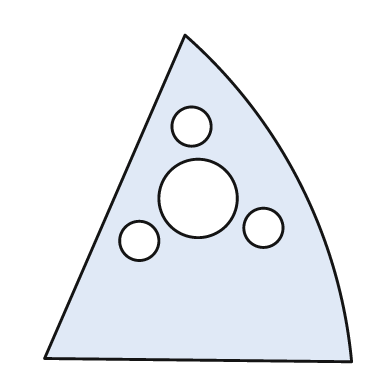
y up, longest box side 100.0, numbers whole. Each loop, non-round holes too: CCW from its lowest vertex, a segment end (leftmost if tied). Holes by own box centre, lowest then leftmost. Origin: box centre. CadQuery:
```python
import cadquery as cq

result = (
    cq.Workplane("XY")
    .moveTo(47.0, -50.0)
    .threePointArc((31.0, 5.0), (-4.0, 50.0))
    .lineTo(-47.0, -49.0)
    .close()
    .moveTo(-18.0, -13.0)
    .circle(6.0)
    .moveTo(20.0, -9.0)
    .circle(6.0)
    .moveTo(0.0, 0.0)
    .circle(12.0)
    .moveTo(-2.0, 22.0)
    .circle(6.0)
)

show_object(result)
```